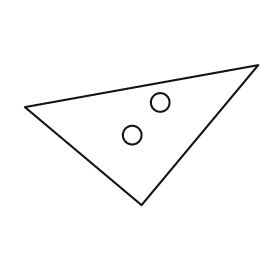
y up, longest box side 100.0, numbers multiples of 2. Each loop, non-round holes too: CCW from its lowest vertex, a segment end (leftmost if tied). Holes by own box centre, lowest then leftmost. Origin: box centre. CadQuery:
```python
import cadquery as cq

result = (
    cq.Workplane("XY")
    .moveTo(0.0, -30.0)
    .lineTo(50.0, 30.0)
    .lineTo(-50.0, 12.0)
    .close()
    .moveTo(-4.0, 0.0)
    .circle(4.0)
    .moveTo(8.0, 14.0)
    .circle(4.0)
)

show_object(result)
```